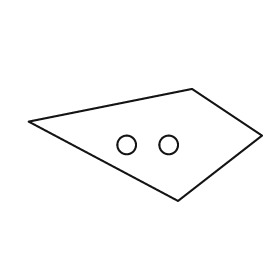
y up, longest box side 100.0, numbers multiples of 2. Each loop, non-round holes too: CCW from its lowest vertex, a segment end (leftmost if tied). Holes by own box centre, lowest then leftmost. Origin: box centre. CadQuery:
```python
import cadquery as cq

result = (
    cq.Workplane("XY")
    .moveTo(14.0, -24.0)
    .lineTo(50.0, 4.0)
    .lineTo(20.0, 24.0)
    .lineTo(-50.0, 10.0)
    .close()
    .moveTo(-8.0, 0.0)
    .circle(4.0)
    .moveTo(10.0, 0.0)
    .circle(4.0)
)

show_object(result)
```